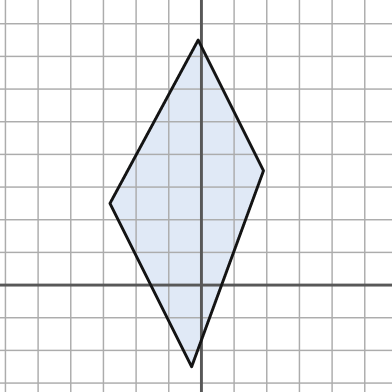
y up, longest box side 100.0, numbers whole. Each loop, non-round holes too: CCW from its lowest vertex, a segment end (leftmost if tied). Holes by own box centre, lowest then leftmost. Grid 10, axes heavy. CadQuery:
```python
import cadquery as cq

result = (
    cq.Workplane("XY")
    .moveTo(-3.0, -25.0)
    .lineTo(19.0, 35.0)
    .lineTo(-1.0, 75.0)
    .lineTo(-28.0, 25.0)
    .close()
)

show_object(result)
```